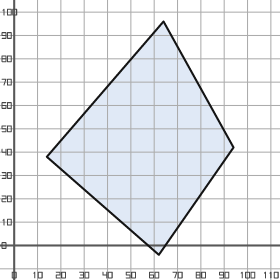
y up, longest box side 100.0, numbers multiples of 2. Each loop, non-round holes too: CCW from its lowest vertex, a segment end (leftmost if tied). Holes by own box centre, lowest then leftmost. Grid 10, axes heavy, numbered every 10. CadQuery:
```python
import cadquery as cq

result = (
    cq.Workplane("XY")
    .moveTo(62.0, -4.0)
    .lineTo(94.0, 42.0)
    .lineTo(64.0, 96.0)
    .lineTo(14.0, 38.0)
    .close()
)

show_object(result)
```